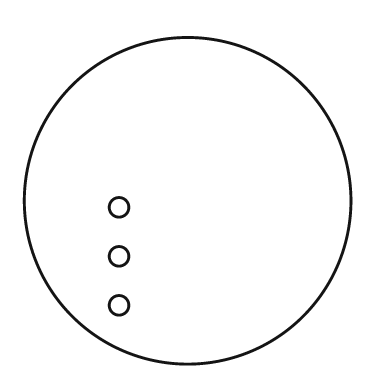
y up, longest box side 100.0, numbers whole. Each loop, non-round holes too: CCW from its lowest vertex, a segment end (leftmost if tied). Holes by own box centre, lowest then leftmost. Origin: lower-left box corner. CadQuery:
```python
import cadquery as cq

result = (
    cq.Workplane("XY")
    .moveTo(50.0, 50.0)
    .circle(50.0)
    .moveTo(29.0, 18.0)
    .circle(3.0)
    .moveTo(29.0, 33.0)
    .circle(3.0)
    .moveTo(29.0, 48.0)
    .circle(3.0)
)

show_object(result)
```